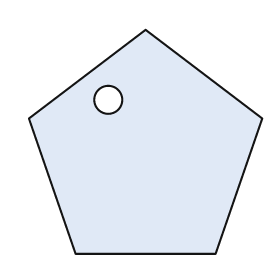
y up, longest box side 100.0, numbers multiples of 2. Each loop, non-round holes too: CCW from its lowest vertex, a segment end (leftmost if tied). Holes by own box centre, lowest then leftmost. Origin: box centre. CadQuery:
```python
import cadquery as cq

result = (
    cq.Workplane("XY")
    .moveTo(-30.0, -48.0)
    .lineTo(30.0, -48.0)
    .lineTo(50.0, 10.0)
    .lineTo(0.0, 48.0)
    .lineTo(-50.0, 10.0)
    .close()
    .moveTo(-16.0, 18.0)
    .circle(6.0)
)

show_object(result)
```